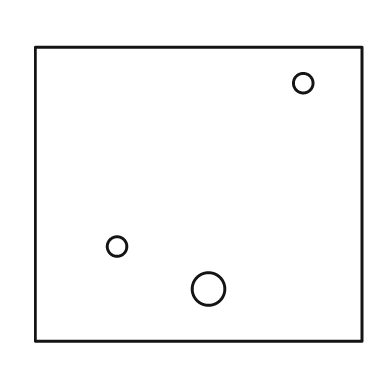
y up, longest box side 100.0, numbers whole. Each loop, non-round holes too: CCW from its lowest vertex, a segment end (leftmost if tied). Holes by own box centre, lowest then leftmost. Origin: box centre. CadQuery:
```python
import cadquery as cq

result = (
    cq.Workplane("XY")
    .moveTo(-50.0, -45.0)
    .lineTo(50.0, -45.0)
    .lineTo(50.0, 45.0)
    .lineTo(-50.0, 45.0)
    .close()
    .moveTo(3.0, -29.0)
    .circle(5.0)
    .moveTo(-25.0, -16.0)
    .circle(3.0)
    .moveTo(32.0, 34.0)
    .circle(3.0)
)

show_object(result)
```